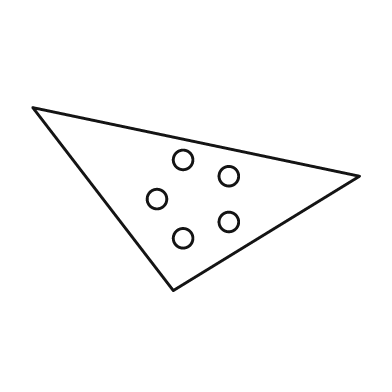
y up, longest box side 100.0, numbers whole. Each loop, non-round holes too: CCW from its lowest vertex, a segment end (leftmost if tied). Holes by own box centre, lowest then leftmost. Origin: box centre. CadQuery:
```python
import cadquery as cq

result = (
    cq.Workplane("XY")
    .moveTo(-7.0, -28.0)
    .lineTo(50.0, 7.0)
    .lineTo(-50.0, 28.0)
    .close()
    .moveTo(-4.0, -12.0)
    .circle(3.0)
    .moveTo(10.0, -7.0)
    .circle(3.0)
    .moveTo(-12.0, 0.0)
    .circle(3.0)
    .moveTo(10.0, 7.0)
    .circle(3.0)
    .moveTo(-4.0, 12.0)
    .circle(3.0)
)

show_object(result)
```